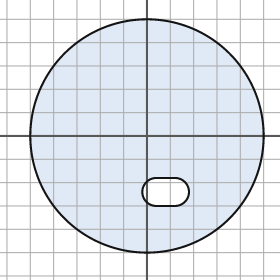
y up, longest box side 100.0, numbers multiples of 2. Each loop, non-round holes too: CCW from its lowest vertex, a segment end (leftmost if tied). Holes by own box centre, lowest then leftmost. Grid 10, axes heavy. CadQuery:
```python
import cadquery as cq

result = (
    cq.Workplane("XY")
    .moveTo(0.0, 0.0)
    .circle(50.0)
    .moveTo(4.0, -30.0)
    .lineTo(12.0, -30.0)
    .threePointArc((18.0, -24.0), (12.0, -18.0))
    .lineTo(4.0, -18.0)
    .threePointArc((-2.0, -24.0), (4.0, -30.0))
    .close()
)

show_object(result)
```